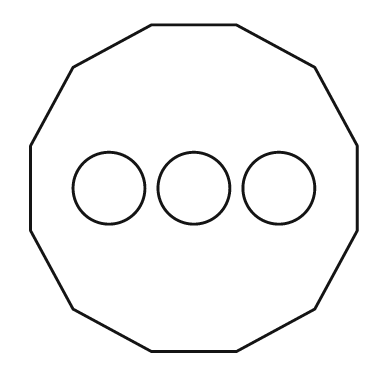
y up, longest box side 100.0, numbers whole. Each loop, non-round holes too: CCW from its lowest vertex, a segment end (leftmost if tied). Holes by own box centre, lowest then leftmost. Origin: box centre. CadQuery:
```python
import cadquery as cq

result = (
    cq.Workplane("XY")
    .moveTo(-13.0, -50.0)
    .lineTo(13.0, -50.0)
    .lineTo(37.0, -37.0)
    .lineTo(50.0, -13.0)
    .lineTo(50.0, 13.0)
    .lineTo(37.0, 37.0)
    .lineTo(13.0, 50.0)
    .lineTo(-13.0, 50.0)
    .lineTo(-37.0, 37.0)
    .lineTo(-50.0, 13.0)
    .lineTo(-50.0, -13.0)
    .lineTo(-37.0, -37.0)
    .close()
    .moveTo(-26.0, 0.0)
    .circle(11.0)
    .moveTo(0.0, 0.0)
    .circle(11.0)
    .moveTo(26.0, 0.0)
    .circle(11.0)
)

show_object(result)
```